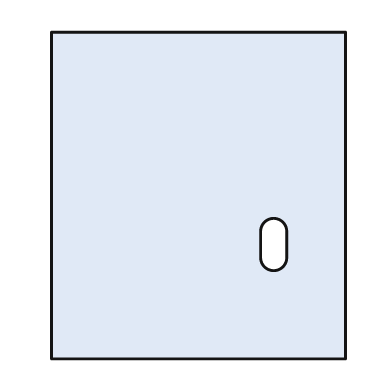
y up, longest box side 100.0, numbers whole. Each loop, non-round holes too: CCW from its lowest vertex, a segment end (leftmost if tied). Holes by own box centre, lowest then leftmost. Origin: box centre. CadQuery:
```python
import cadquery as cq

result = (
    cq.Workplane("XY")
    .moveTo(-45.0, -50.0)
    .lineTo(45.0, -50.0)
    .lineTo(45.0, 50.0)
    .lineTo(-45.0, 50.0)
    .close()
    .moveTo(19.0, -19.0)
    .threePointArc((23.0, -23.0), (27.0, -19.0))
    .lineTo(27.0, -11.0)
    .threePointArc((23.0, -7.0), (19.0, -11.0))
    .close()
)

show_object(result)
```